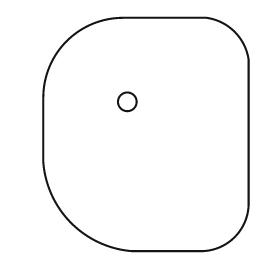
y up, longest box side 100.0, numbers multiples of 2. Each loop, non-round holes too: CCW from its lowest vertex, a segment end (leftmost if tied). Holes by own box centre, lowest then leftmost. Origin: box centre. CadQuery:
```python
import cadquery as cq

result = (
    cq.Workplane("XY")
    .moveTo(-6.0, -50.0)
    .lineTo(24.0, -50.0)
    .threePointArc((38.0, -44.0), (44.0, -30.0))
    .lineTo(44.0, 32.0)
    .threePointArc((38.0, 44.0), (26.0, 50.0))
    .lineTo(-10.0, 50.0)
    .threePointArc((-34.0, 40.0), (-44.0, 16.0))
    .lineTo(-44.0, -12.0)
    .threePointArc((-32.0, -38.0), (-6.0, -50.0))
    .close()
    .moveTo(-8.0, 14.0)
    .circle(4.0)
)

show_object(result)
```